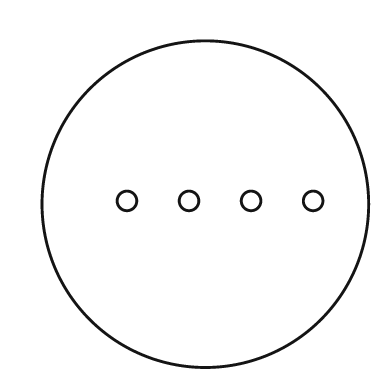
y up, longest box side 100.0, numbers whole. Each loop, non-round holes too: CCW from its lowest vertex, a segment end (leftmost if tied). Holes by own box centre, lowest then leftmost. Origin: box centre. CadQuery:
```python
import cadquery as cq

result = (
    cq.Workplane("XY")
    .moveTo(0.0, 0.0)
    .circle(50.0)
    .moveTo(-24.0, 1.0)
    .circle(3.0)
    .moveTo(-5.0, 1.0)
    .circle(3.0)
    .moveTo(14.0, 1.0)
    .circle(3.0)
    .moveTo(33.0, 1.0)
    .circle(3.0)
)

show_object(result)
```